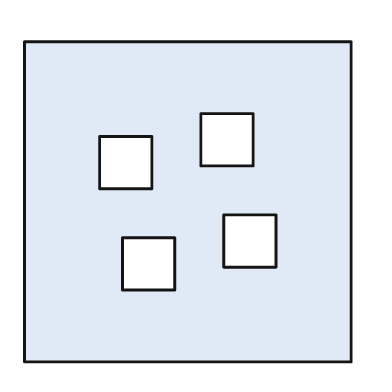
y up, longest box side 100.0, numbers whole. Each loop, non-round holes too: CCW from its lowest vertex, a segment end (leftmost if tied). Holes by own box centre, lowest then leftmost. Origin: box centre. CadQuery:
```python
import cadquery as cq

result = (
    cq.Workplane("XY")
    .moveTo(-50.0, -49.0)
    .lineTo(50.0, -49.0)
    .lineTo(50.0, 49.0)
    .lineTo(-50.0, 49.0)
    .close()
    .moveTo(-20.0, -27.0)
    .lineTo(-4.0, -27.0)
    .lineTo(-4.0, -11.0)
    .lineTo(-20.0, -11.0)
    .close()
    .moveTo(11.0, -20.0)
    .lineTo(27.0, -20.0)
    .lineTo(27.0, -4.0)
    .lineTo(11.0, -4.0)
    .close()
    .moveTo(-27.0, 4.0)
    .lineTo(-11.0, 4.0)
    .lineTo(-11.0, 20.0)
    .lineTo(-27.0, 20.0)
    .close()
    .moveTo(4.0, 11.0)
    .lineTo(20.0, 11.0)
    .lineTo(20.0, 27.0)
    .lineTo(4.0, 27.0)
    .close()
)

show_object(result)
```